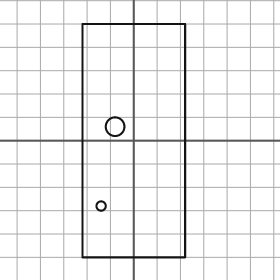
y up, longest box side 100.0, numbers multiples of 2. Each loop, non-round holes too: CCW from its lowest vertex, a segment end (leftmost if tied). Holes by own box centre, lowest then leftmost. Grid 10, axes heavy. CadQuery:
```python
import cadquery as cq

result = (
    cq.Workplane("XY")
    .moveTo(-22.0, -50.0)
    .lineTo(22.0, -50.0)
    .lineTo(22.0, 50.0)
    .lineTo(-22.0, 50.0)
    .close()
    .moveTo(-14.0, -28.0)
    .circle(2.0)
    .moveTo(-8.0, 6.0)
    .circle(4.0)
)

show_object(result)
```